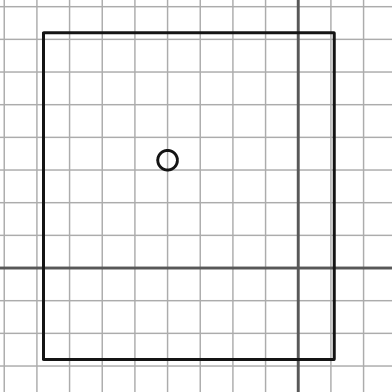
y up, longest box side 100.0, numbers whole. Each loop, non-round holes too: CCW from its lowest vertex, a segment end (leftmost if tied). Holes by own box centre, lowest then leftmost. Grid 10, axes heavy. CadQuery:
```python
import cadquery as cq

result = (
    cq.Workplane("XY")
    .moveTo(-78.0, -28.0)
    .lineTo(11.0, -28.0)
    .lineTo(11.0, 72.0)
    .lineTo(-78.0, 72.0)
    .close()
    .moveTo(-40.0, 33.0)
    .circle(3.0)
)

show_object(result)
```